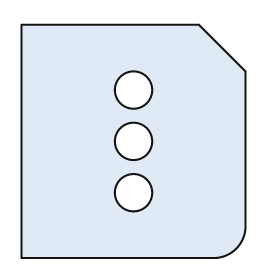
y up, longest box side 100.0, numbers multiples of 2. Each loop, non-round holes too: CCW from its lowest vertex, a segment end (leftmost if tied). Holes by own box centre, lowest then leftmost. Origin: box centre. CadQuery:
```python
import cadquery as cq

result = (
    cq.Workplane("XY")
    .moveTo(-48.0, -50.0)
    .lineTo(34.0, -50.0)
    .threePointArc((44.0, -46.0), (48.0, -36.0))
    .lineTo(48.0, 30.0)
    .lineTo(28.0, 50.0)
    .lineTo(-48.0, 50.0)
    .close()
    .moveTo(0.0, -22.0)
    .circle(8.0)
    .moveTo(0.0, 0.0)
    .circle(8.0)
    .moveTo(0.0, 22.0)
    .circle(8.0)
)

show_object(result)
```